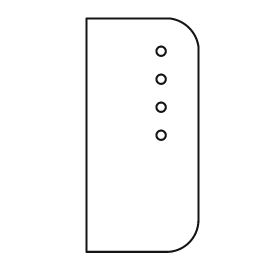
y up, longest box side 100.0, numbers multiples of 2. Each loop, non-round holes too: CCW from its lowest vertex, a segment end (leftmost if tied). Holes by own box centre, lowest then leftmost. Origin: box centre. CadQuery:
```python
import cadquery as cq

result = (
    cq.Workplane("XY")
    .moveTo(-24.0, -50.0)
    .lineTo(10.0, -50.0)
    .threePointArc((20.0, -46.0), (24.0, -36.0))
    .lineTo(24.0, 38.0)
    .threePointArc((20.0, 46.0), (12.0, 50.0))
    .lineTo(-24.0, 50.0)
    .close()
    .moveTo(8.0, 0.0)
    .circle(2.0)
    .moveTo(8.0, 12.0)
    .circle(2.0)
    .moveTo(8.0, 24.0)
    .circle(2.0)
    .moveTo(8.0, 36.0)
    .circle(2.0)
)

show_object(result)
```